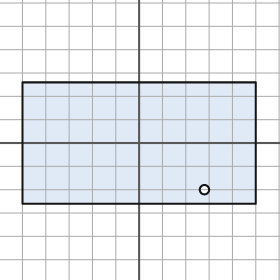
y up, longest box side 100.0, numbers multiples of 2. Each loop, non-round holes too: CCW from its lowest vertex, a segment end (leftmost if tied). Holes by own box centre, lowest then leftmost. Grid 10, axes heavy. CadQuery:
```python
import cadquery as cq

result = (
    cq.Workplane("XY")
    .moveTo(-50.0, -26.0)
    .lineTo(50.0, -26.0)
    .lineTo(50.0, 26.0)
    .lineTo(-50.0, 26.0)
    .close()
    .moveTo(28.0, -20.0)
    .circle(2.0)
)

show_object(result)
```